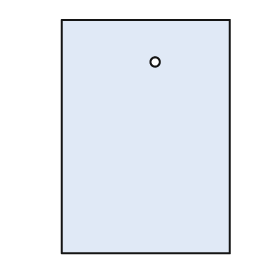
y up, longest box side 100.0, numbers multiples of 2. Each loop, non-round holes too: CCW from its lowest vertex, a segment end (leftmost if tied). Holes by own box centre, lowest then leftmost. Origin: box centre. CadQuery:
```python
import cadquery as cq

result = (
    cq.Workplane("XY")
    .moveTo(-36.0, -50.0)
    .lineTo(36.0, -50.0)
    .lineTo(36.0, 50.0)
    .lineTo(-36.0, 50.0)
    .close()
    .moveTo(4.0, 32.0)
    .circle(2.0)
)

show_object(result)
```